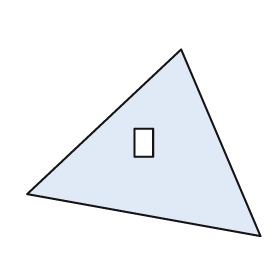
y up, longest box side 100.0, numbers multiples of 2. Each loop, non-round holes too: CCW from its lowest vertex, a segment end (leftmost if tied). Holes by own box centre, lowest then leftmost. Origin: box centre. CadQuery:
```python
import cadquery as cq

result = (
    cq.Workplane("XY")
    .moveTo(50.0, -40.0)
    .lineTo(16.0, 40.0)
    .lineTo(-50.0, -22.0)
    .close()
    .moveTo(-4.0, -6.0)
    .lineTo(4.0, -6.0)
    .lineTo(4.0, 6.0)
    .lineTo(-4.0, 6.0)
    .close()
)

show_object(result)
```